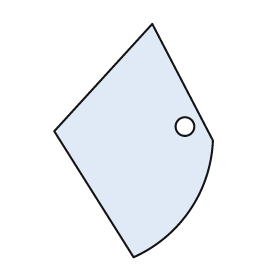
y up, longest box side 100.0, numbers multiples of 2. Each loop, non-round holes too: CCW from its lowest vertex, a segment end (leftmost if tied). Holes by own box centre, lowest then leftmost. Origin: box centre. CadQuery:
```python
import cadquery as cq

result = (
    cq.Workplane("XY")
    .moveTo(0.0, -50.0)
    .threePointArc((24.0, -30.0), (34.0, 0.0))
    .lineTo(8.0, 50.0)
    .lineTo(-34.0, 4.0)
    .close()
    .moveTo(22.0, 6.0)
    .circle(4.0)
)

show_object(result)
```